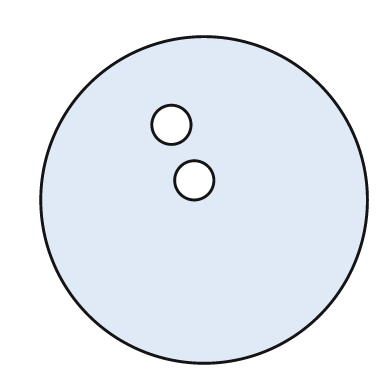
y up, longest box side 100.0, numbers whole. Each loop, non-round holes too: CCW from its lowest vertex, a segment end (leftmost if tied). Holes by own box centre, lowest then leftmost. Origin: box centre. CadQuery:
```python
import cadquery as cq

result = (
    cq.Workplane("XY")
    .moveTo(0.0, 0.0)
    .circle(50.0)
    .moveTo(-3.0, 6.0)
    .circle(6.0)
    .moveTo(-10.0, 23.0)
    .circle(6.0)
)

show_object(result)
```